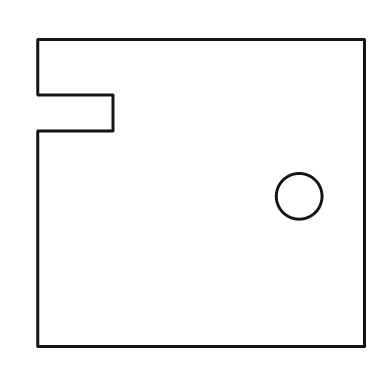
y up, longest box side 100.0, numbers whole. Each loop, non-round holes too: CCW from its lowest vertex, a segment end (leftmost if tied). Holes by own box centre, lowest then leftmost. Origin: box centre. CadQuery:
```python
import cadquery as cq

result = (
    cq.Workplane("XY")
    .moveTo(-50.0, -47.0)
    .lineTo(50.0, -47.0)
    .lineTo(50.0, 47.0)
    .lineTo(-50.0, 47.0)
    .lineTo(-50.0, 30.0)
    .lineTo(-27.0, 30.0)
    .lineTo(-27.0, 19.0)
    .lineTo(-50.0, 19.0)
    .close()
    .moveTo(30.0, -1.0)
    .circle(7.0)
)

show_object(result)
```